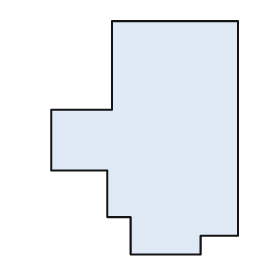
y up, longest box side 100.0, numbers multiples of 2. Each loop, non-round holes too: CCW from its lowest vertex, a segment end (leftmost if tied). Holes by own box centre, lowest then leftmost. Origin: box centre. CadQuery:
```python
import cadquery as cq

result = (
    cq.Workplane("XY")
    .moveTo(-6.0, -50.0)
    .lineTo(24.0, -50.0)
    .lineTo(24.0, -42.0)
    .lineTo(40.0, -42.0)
    .lineTo(40.0, 50.0)
    .lineTo(-14.0, 50.0)
    .lineTo(-14.0, 12.0)
    .lineTo(-40.0, 12.0)
    .lineTo(-40.0, -14.0)
    .lineTo(-16.0, -14.0)
    .lineTo(-16.0, -34.0)
    .lineTo(-6.0, -34.0)
    .close()
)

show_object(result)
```